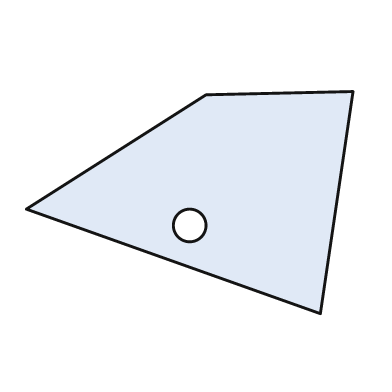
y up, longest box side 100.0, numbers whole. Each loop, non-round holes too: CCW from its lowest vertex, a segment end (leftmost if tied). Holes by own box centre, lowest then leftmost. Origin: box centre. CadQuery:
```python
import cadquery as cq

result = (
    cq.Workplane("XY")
    .moveTo(40.0, -34.0)
    .lineTo(50.0, 34.0)
    .lineTo(5.0, 33.0)
    .lineTo(-50.0, -2.0)
    .close()
    .moveTo(0.0, -7.0)
    .circle(5.0)
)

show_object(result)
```